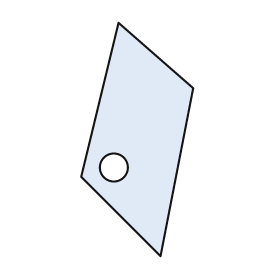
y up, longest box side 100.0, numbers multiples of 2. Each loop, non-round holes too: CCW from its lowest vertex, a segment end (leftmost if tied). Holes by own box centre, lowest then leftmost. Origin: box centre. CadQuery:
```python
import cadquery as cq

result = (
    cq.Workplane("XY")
    .moveTo(10.0, -50.0)
    .lineTo(24.0, 22.0)
    .lineTo(-8.0, 50.0)
    .lineTo(-24.0, -16.0)
    .close()
    .moveTo(-10.0, -12.0)
    .circle(6.0)
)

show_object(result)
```